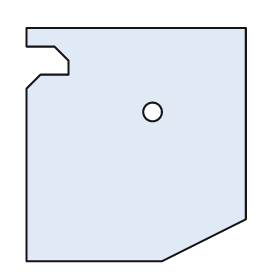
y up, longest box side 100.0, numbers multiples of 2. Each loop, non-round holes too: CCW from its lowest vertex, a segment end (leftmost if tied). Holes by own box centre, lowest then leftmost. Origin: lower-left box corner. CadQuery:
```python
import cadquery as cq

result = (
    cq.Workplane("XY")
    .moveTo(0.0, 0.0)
    .lineTo(58.0, 0.0)
    .lineTo(94.0, 18.0)
    .lineTo(94.0, 100.0)
    .lineTo(0.0, 100.0)
    .lineTo(0.0, 92.0)
    .lineTo(12.0, 92.0)
    .lineTo(18.0, 86.0)
    .lineTo(18.0, 80.0)
    .lineTo(6.0, 80.0)
    .lineTo(0.0, 74.0)
    .close()
    .moveTo(54.0, 64.0)
    .circle(4.0)
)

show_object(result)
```